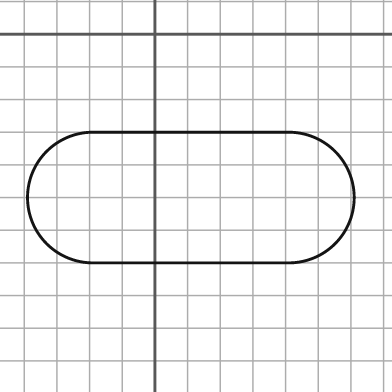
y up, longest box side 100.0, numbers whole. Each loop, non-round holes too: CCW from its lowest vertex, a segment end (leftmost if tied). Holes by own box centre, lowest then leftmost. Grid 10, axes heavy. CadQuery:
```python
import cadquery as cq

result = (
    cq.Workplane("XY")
    .moveTo(-19.0, -70.0)
    .lineTo(41.0, -70.0)
    .threePointArc((61.0, -50.0), (41.0, -30.0))
    .lineTo(-19.0, -30.0)
    .threePointArc((-39.0, -50.0), (-19.0, -70.0))
    .close()
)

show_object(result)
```